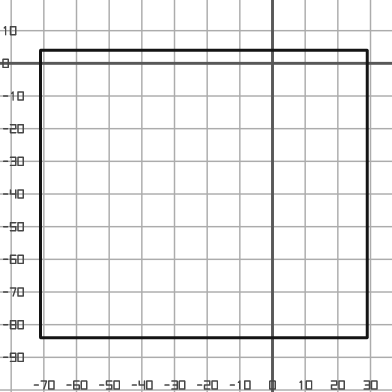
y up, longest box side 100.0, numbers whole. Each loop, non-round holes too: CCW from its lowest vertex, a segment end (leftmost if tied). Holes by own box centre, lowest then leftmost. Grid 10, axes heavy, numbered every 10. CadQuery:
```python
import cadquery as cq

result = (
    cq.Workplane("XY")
    .moveTo(-71.0, -84.0)
    .lineTo(29.0, -84.0)
    .lineTo(29.0, 4.0)
    .lineTo(-71.0, 4.0)
    .close()
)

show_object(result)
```